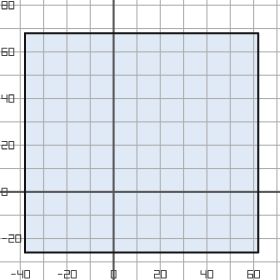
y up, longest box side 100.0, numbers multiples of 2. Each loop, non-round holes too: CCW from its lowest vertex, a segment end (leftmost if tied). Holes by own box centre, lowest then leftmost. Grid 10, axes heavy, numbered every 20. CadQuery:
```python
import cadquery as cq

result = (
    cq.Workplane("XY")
    .moveTo(-38.0, -26.0)
    .lineTo(62.0, -26.0)
    .lineTo(62.0, 68.0)
    .lineTo(-38.0, 68.0)
    .close()
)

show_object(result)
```